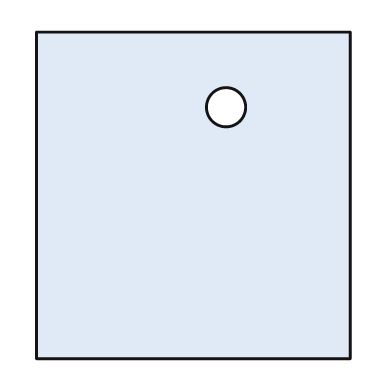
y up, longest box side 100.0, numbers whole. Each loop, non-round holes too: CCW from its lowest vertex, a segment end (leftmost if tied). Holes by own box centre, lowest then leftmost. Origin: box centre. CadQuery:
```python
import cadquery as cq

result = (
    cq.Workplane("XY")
    .moveTo(-48.0, -50.0)
    .lineTo(48.0, -50.0)
    .lineTo(48.0, 50.0)
    .lineTo(-48.0, 50.0)
    .close()
    .moveTo(10.0, 27.0)
    .circle(6.0)
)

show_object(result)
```